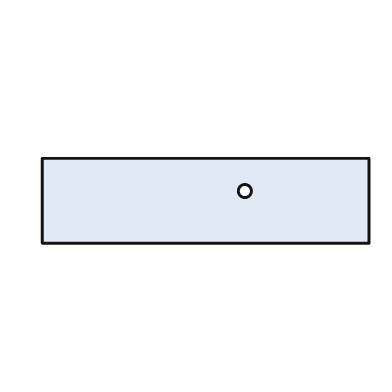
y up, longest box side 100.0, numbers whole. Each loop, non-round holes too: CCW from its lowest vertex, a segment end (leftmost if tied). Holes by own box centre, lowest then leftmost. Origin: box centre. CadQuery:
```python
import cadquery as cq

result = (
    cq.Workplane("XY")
    .moveTo(-50.0, -13.0)
    .lineTo(50.0, -13.0)
    .lineTo(50.0, 13.0)
    .lineTo(-50.0, 13.0)
    .close()
    .moveTo(12.0, 3.0)
    .circle(2.0)
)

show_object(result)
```